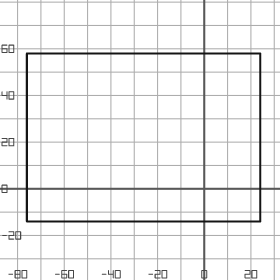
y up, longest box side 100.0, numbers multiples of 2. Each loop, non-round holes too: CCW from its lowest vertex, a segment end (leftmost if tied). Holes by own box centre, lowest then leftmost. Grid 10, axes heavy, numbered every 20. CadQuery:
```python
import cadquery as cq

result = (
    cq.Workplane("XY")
    .moveTo(-76.0, -14.0)
    .lineTo(24.0, -14.0)
    .lineTo(24.0, 58.0)
    .lineTo(-76.0, 58.0)
    .close()
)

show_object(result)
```